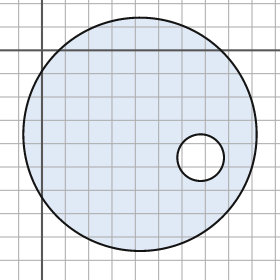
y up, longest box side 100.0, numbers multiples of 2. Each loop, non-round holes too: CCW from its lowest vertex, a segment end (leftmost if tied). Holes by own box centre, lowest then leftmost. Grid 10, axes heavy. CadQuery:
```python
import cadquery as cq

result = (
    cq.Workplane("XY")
    .moveTo(42.0, -36.0)
    .circle(50.0)
    .moveTo(68.0, -46.0)
    .circle(10.0)
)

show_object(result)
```